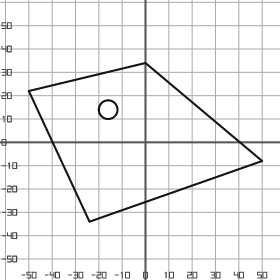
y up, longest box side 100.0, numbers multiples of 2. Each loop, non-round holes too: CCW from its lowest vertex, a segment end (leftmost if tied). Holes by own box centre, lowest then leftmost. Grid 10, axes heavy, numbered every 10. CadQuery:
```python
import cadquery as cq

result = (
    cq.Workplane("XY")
    .moveTo(-24.0, -34.0)
    .lineTo(50.0, -8.0)
    .lineTo(0.0, 34.0)
    .lineTo(-50.0, 22.0)
    .close()
    .moveTo(-16.0, 14.0)
    .circle(4.0)
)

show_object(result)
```